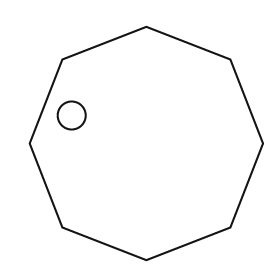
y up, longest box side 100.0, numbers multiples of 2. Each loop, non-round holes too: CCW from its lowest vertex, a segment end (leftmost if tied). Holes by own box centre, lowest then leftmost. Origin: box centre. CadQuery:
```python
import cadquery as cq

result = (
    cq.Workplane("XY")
    .moveTo(0.0, -50.0)
    .lineTo(36.0, -36.0)
    .lineTo(50.0, 0.0)
    .lineTo(36.0, 36.0)
    .lineTo(0.0, 50.0)
    .lineTo(-36.0, 36.0)
    .lineTo(-50.0, 0.0)
    .lineTo(-36.0, -36.0)
    .close()
    .moveTo(-32.0, 12.0)
    .circle(6.0)
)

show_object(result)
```